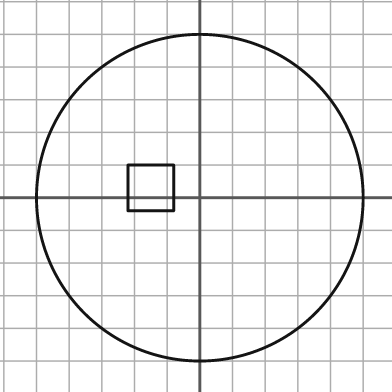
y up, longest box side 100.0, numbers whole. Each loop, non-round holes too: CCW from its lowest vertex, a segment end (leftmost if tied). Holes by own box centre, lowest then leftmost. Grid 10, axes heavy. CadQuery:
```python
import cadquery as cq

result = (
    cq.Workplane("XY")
    .moveTo(0.0, 0.0)
    .circle(50.0)
    .moveTo(-22.0, -4.0)
    .lineTo(-8.0, -4.0)
    .lineTo(-8.0, 10.0)
    .lineTo(-22.0, 10.0)
    .close()
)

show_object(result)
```